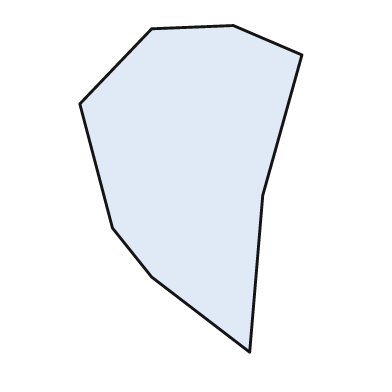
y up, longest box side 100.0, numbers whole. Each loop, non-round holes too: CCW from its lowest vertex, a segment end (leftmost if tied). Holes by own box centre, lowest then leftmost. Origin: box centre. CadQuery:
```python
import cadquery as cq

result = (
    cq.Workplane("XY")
    .moveTo(18.0, -50.0)
    .lineTo(22.0, -2.0)
    .lineTo(34.0, 41.0)
    .lineTo(13.0, 50.0)
    .lineTo(-12.0, 49.0)
    .lineTo(-34.0, 26.0)
    .lineTo(-24.0, -12.0)
    .lineTo(-12.0, -27.0)
    .close()
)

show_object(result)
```